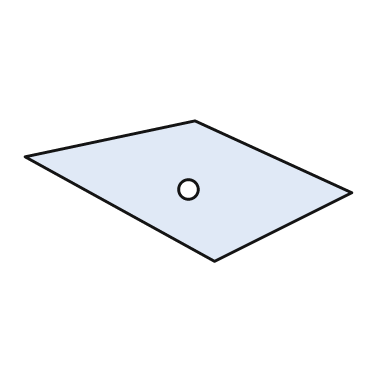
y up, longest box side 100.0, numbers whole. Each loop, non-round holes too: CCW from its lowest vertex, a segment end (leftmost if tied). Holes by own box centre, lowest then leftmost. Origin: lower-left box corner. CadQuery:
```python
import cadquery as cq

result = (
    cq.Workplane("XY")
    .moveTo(58.0, 0.0)
    .lineTo(100.0, 21.0)
    .lineTo(52.0, 43.0)
    .lineTo(0.0, 32.0)
    .close()
    .moveTo(50.0, 22.0)
    .circle(3.0)
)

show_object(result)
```